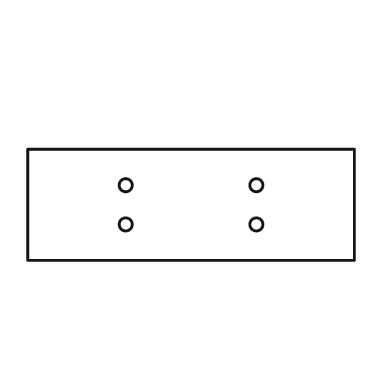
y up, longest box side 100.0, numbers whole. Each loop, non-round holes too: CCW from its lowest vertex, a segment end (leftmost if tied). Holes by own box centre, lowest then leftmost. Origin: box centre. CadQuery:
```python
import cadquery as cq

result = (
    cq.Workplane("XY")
    .moveTo(-50.0, -17.0)
    .lineTo(50.0, -17.0)
    .lineTo(50.0, 17.0)
    .lineTo(-50.0, 17.0)
    .close()
    .moveTo(-20.0, -6.0)
    .circle(2.0)
    .moveTo(20.0, -6.0)
    .circle(2.0)
    .moveTo(-20.0, 6.0)
    .circle(2.0)
    .moveTo(20.0, 6.0)
    .circle(2.0)
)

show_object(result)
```